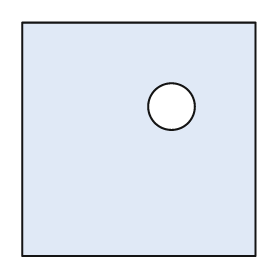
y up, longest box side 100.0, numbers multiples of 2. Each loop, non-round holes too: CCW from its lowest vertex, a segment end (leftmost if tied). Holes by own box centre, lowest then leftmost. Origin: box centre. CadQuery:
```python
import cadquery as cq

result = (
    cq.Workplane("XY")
    .moveTo(-50.0, -50.0)
    .lineTo(50.0, -50.0)
    .lineTo(50.0, 50.0)
    .lineTo(-50.0, 50.0)
    .close()
    .moveTo(14.0, 14.0)
    .circle(10.0)
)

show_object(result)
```